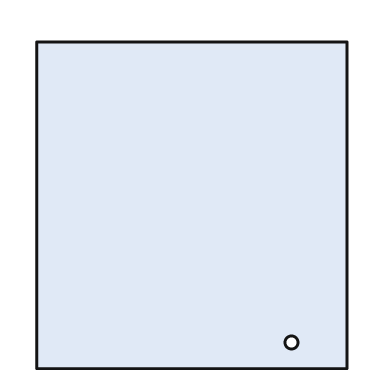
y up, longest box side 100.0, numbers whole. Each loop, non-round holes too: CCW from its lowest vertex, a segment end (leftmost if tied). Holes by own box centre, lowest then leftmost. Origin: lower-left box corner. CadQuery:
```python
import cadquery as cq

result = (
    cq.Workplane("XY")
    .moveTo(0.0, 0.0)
    .lineTo(95.0, 0.0)
    .lineTo(95.0, 100.0)
    .lineTo(0.0, 100.0)
    .close()
    .moveTo(78.0, 8.0)
    .circle(2.0)
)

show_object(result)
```